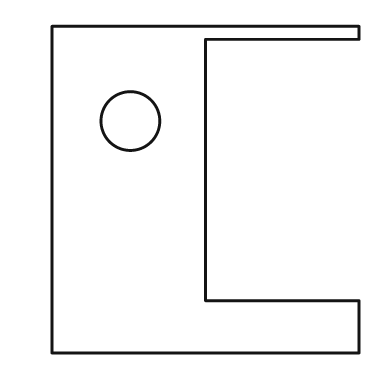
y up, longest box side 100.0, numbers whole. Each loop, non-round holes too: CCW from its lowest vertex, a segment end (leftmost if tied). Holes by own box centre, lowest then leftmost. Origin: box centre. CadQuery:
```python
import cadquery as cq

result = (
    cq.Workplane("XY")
    .moveTo(-47.0, -50.0)
    .lineTo(47.0, -50.0)
    .lineTo(47.0, -34.0)
    .lineTo(0.0, -34.0)
    .lineTo(0.0, 46.0)
    .lineTo(47.0, 46.0)
    .lineTo(47.0, 50.0)
    .lineTo(-47.0, 50.0)
    .close()
    .moveTo(-23.0, 21.0)
    .circle(9.0)
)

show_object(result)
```